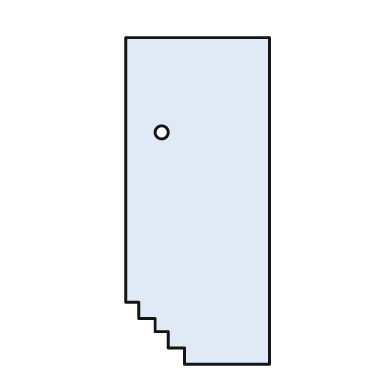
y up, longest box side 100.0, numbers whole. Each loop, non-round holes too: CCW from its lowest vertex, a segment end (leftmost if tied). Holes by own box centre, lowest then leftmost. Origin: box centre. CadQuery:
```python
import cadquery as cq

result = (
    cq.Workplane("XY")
    .moveTo(-4.0, -50.0)
    .lineTo(22.0, -50.0)
    .lineTo(22.0, 50.0)
    .lineTo(-22.0, 50.0)
    .lineTo(-22.0, -31.0)
    .lineTo(-18.0, -31.0)
    .lineTo(-18.0, -36.0)
    .lineTo(-13.0, -36.0)
    .lineTo(-13.0, -40.0)
    .lineTo(-9.0, -40.0)
    .lineTo(-9.0, -45.0)
    .lineTo(-4.0, -45.0)
    .close()
    .moveTo(-11.0, 21.0)
    .circle(2.0)
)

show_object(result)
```